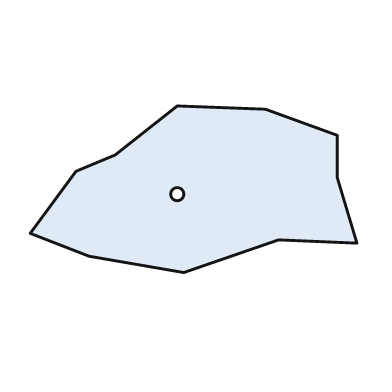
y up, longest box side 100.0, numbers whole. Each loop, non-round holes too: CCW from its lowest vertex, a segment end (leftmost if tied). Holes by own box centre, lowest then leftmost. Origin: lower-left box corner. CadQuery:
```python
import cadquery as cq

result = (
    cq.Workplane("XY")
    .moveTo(47.0, 0.0)
    .lineTo(76.0, 10.0)
    .lineTo(100.0, 9.0)
    .lineTo(94.0, 29.0)
    .lineTo(94.0, 42.0)
    .lineTo(72.0, 50.0)
    .lineTo(45.0, 51.0)
    .lineTo(26.0, 36.0)
    .lineTo(14.0, 31.0)
    .lineTo(0.0, 12.0)
    .lineTo(18.0, 5.0)
    .close()
    .moveTo(45.0, 24.0)
    .circle(2.0)
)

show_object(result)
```